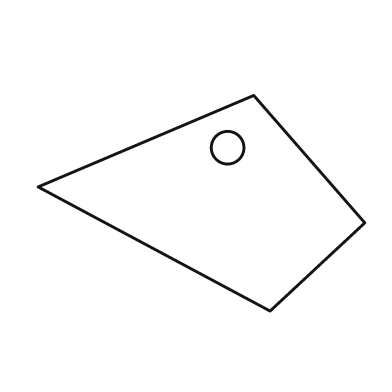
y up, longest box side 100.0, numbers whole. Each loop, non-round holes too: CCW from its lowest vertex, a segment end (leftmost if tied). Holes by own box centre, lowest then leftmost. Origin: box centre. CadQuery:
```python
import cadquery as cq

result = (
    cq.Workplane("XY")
    .moveTo(21.0, -33.0)
    .lineTo(50.0, -6.0)
    .lineTo(16.0, 33.0)
    .lineTo(-50.0, 5.0)
    .close()
    .moveTo(8.0, 17.0)
    .circle(5.0)
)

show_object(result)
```